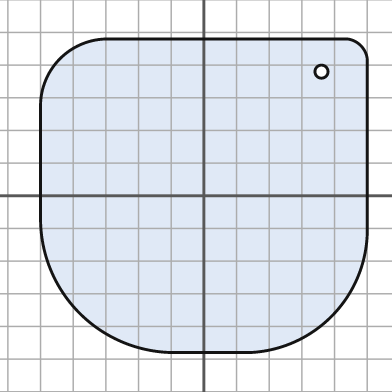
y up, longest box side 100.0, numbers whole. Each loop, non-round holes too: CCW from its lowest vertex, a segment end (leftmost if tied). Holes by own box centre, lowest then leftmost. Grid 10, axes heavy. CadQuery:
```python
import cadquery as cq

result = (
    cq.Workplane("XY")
    .moveTo(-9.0, -48.0)
    .lineTo(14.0, -48.0)
    .threePointArc((39.0, -37.0), (50.0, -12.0))
    .lineTo(50.0, 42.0)
    .threePointArc((48.0, 46.0), (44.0, 48.0))
    .lineTo(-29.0, 48.0)
    .threePointArc((-44.0, 42.0), (-50.0, 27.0))
    .lineTo(-50.0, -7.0)
    .threePointArc((-38.0, -36.0), (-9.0, -48.0))
    .close()
    .moveTo(36.0, 38.0)
    .circle(2.0)
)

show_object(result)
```